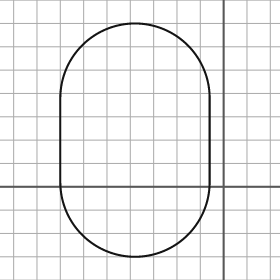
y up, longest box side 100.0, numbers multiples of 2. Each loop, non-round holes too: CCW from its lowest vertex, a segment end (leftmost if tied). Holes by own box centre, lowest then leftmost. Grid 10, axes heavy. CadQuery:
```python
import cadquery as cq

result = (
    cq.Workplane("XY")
    .moveTo(-70.0, 2.0)
    .threePointArc((-38.0, -30.0), (-6.0, 2.0))
    .lineTo(-6.0, 38.0)
    .threePointArc((-38.0, 70.0), (-70.0, 38.0))
    .close()
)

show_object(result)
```